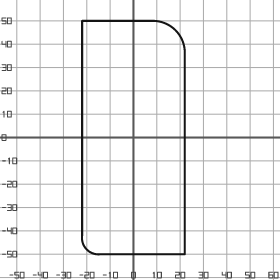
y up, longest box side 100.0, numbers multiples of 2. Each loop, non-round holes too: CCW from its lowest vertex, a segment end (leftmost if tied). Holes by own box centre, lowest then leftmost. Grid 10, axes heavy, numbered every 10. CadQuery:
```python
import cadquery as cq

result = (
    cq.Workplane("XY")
    .moveTo(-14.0, -50.0)
    .lineTo(22.0, -50.0)
    .lineTo(22.0, 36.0)
    .threePointArc((18.0, 46.0), (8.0, 50.0))
    .lineTo(-22.0, 50.0)
    .lineTo(-22.0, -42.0)
    .threePointArc((-20.0, -48.0), (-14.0, -50.0))
    .close()
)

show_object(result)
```